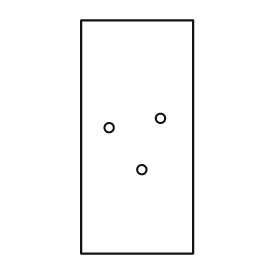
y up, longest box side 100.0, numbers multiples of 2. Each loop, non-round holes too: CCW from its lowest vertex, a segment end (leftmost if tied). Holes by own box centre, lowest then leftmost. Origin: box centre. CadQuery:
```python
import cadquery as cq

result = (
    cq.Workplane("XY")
    .moveTo(-24.0, -50.0)
    .lineTo(24.0, -50.0)
    .lineTo(24.0, 50.0)
    .lineTo(-24.0, 50.0)
    .close()
    .moveTo(2.0, -14.0)
    .circle(2.0)
    .moveTo(-12.0, 4.0)
    .circle(2.0)
    .moveTo(10.0, 8.0)
    .circle(2.0)
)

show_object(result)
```